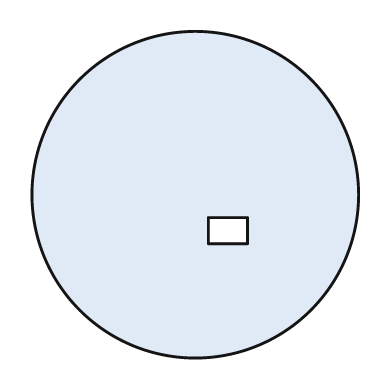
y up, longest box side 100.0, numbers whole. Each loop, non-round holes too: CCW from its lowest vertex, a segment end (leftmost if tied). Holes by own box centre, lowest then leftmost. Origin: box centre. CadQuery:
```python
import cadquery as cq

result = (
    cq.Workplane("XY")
    .moveTo(0.0, 0.0)
    .circle(50.0)
    .moveTo(4.0, -15.0)
    .lineTo(16.0, -15.0)
    .lineTo(16.0, -7.0)
    .lineTo(4.0, -7.0)
    .close()
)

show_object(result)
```